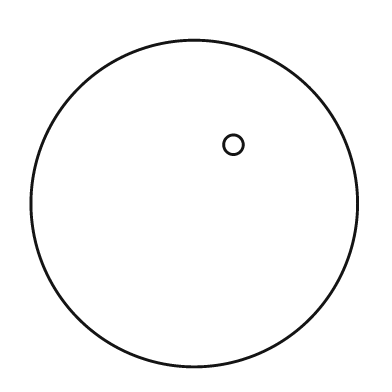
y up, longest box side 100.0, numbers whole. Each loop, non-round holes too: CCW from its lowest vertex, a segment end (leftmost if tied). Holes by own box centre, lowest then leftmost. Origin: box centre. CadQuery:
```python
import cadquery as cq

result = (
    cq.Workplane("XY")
    .moveTo(0.0, 0.0)
    .circle(50.0)
    .moveTo(12.0, 18.0)
    .circle(3.0)
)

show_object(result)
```